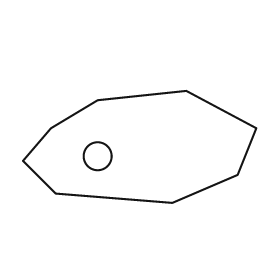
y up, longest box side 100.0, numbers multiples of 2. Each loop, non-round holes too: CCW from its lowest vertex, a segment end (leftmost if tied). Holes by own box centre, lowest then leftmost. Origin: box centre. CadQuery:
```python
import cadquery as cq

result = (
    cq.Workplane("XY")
    .moveTo(14.0, -24.0)
    .lineTo(42.0, -12.0)
    .lineTo(50.0, 8.0)
    .lineTo(20.0, 24.0)
    .lineTo(-18.0, 20.0)
    .lineTo(-38.0, 8.0)
    .lineTo(-50.0, -6.0)
    .lineTo(-36.0, -20.0)
    .close()
    .moveTo(-18.0, -4.0)
    .circle(6.0)
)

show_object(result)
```